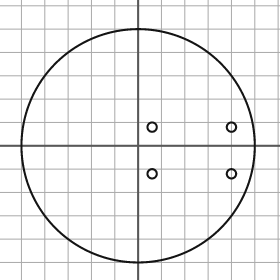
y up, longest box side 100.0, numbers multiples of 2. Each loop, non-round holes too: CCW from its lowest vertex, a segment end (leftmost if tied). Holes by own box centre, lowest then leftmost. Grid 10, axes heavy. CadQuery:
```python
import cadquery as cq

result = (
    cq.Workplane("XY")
    .moveTo(0.0, 0.0)
    .circle(50.0)
    .moveTo(6.0, -12.0)
    .circle(2.0)
    .moveTo(40.0, -12.0)
    .circle(2.0)
    .moveTo(6.0, 8.0)
    .circle(2.0)
    .moveTo(40.0, 8.0)
    .circle(2.0)
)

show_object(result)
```